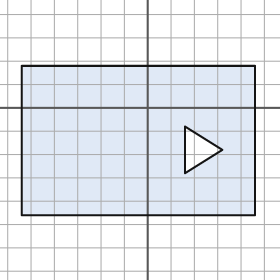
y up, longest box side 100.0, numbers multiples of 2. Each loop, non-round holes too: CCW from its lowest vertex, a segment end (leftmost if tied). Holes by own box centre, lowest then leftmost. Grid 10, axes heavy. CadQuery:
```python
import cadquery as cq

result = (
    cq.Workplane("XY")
    .moveTo(-54.0, -46.0)
    .lineTo(46.0, -46.0)
    .lineTo(46.0, 18.0)
    .lineTo(-54.0, 18.0)
    .close()
    .moveTo(16.0, -28.0)
    .lineTo(32.0, -18.0)
    .lineTo(16.0, -8.0)
    .close()
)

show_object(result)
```